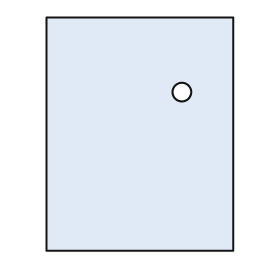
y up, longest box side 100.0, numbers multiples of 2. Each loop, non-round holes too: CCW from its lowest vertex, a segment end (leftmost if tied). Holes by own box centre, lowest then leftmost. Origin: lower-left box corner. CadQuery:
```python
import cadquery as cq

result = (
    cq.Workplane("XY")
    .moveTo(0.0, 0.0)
    .lineTo(80.0, 0.0)
    .lineTo(80.0, 100.0)
    .lineTo(0.0, 100.0)
    .close()
    .moveTo(58.0, 68.0)
    .circle(4.0)
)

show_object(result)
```